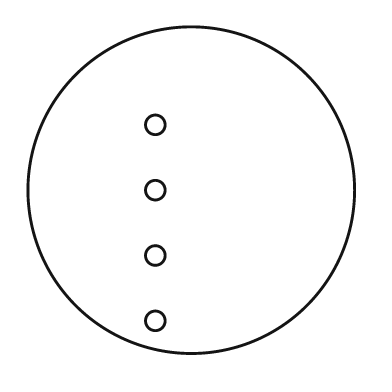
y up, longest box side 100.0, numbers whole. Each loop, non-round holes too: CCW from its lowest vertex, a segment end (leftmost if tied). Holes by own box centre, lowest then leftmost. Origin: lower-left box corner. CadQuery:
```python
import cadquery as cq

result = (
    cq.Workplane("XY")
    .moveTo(50.0, 50.0)
    .circle(50.0)
    .moveTo(39.0, 10.0)
    .circle(3.0)
    .moveTo(39.0, 30.0)
    .circle(3.0)
    .moveTo(39.0, 50.0)
    .circle(3.0)
    .moveTo(39.0, 70.0)
    .circle(3.0)
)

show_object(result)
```